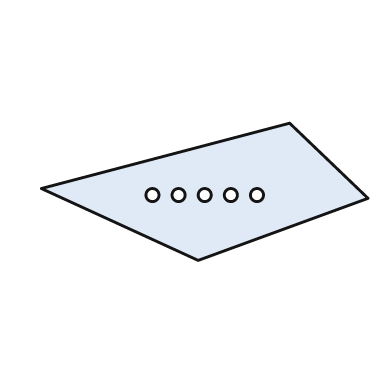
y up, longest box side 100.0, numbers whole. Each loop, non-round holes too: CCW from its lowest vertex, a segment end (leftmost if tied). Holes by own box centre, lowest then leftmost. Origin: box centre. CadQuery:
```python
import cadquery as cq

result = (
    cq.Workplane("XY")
    .moveTo(-2.0, -21.0)
    .lineTo(50.0, -2.0)
    .lineTo(26.0, 21.0)
    .lineTo(-50.0, 1.0)
    .close()
    .moveTo(-16.0, -1.0)
    .circle(2.0)
    .moveTo(-8.0, -1.0)
    .circle(2.0)
    .moveTo(0.0, -1.0)
    .circle(2.0)
    .moveTo(8.0, -1.0)
    .circle(2.0)
    .moveTo(16.0, -1.0)
    .circle(2.0)
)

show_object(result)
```